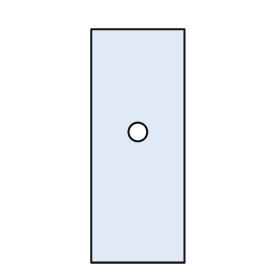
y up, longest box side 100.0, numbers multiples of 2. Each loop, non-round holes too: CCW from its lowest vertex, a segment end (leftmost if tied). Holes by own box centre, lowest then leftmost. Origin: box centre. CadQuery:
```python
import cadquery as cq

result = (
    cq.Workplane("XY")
    .moveTo(-20.0, -50.0)
    .lineTo(20.0, -50.0)
    .lineTo(20.0, 50.0)
    .lineTo(-20.0, 50.0)
    .close()
    .moveTo(0.0, 6.0)
    .circle(4.0)
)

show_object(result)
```